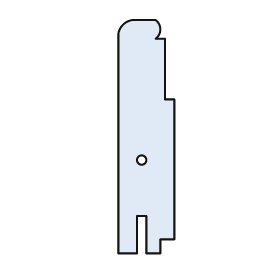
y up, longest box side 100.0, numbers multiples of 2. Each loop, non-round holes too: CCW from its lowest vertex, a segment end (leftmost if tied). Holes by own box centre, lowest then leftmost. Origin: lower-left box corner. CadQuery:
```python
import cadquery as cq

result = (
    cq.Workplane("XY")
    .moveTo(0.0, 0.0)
    .lineTo(8.0, 0.0)
    .lineTo(8.0, 16.0)
    .lineTo(12.0, 16.0)
    .lineTo(12.0, 0.0)
    .lineTo(18.0, 0.0)
    .lineTo(18.0, 6.0)
    .lineTo(24.0, 6.0)
    .lineTo(24.0, 66.0)
    .lineTo(20.0, 66.0)
    .lineTo(20.0, 92.0)
    .lineTo(16.0, 92.0)
    .threePointArc((18.0, 96.0), (16.0, 100.0))
    .lineTo(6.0, 100.0)
    .threePointArc((2.0, 98.0), (0.0, 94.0))
    .close()
    .moveTo(10.0, 40.0)
    .circle(2.0)
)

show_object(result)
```